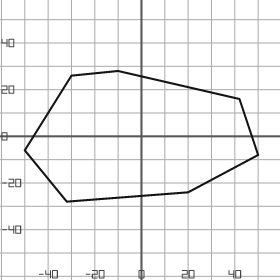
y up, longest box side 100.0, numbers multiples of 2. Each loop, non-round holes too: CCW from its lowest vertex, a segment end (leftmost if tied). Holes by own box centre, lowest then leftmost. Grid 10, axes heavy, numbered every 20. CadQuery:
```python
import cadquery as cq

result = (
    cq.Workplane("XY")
    .moveTo(-32.0, -28.0)
    .lineTo(20.0, -24.0)
    .lineTo(50.0, -8.0)
    .lineTo(42.0, 16.0)
    .lineTo(-10.0, 28.0)
    .lineTo(-30.0, 26.0)
    .lineTo(-50.0, -6.0)
    .close()
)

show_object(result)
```